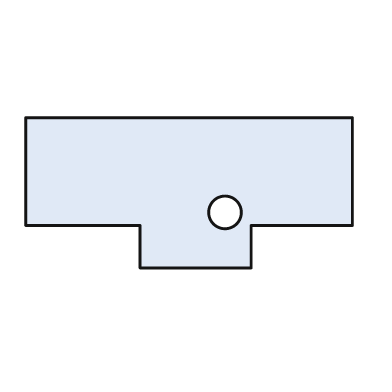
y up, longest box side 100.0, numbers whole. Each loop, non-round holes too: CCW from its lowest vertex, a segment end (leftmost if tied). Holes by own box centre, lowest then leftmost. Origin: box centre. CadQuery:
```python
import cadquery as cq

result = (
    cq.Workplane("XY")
    .moveTo(-15.0, -23.0)
    .lineTo(19.0, -23.0)
    .lineTo(19.0, -10.0)
    .lineTo(50.0, -10.0)
    .lineTo(50.0, 23.0)
    .lineTo(-50.0, 23.0)
    .lineTo(-50.0, -10.0)
    .lineTo(-15.0, -10.0)
    .close()
    .moveTo(11.0, -6.0)
    .circle(5.0)
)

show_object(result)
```